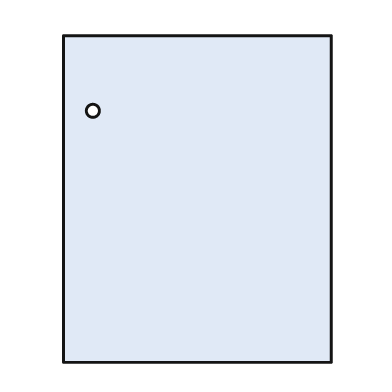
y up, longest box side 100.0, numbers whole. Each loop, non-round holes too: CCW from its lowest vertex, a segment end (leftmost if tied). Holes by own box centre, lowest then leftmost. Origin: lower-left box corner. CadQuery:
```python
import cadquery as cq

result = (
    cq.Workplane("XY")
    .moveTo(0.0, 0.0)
    .lineTo(82.0, 0.0)
    .lineTo(82.0, 100.0)
    .lineTo(0.0, 100.0)
    .close()
    .moveTo(9.0, 77.0)
    .circle(2.0)
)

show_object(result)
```